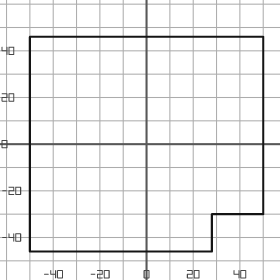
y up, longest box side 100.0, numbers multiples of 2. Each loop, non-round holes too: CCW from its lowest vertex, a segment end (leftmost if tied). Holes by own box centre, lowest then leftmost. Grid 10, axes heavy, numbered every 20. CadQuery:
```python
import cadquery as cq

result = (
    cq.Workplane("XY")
    .moveTo(-50.0, -46.0)
    .lineTo(28.0, -46.0)
    .lineTo(28.0, -30.0)
    .lineTo(50.0, -30.0)
    .lineTo(50.0, 46.0)
    .lineTo(-50.0, 46.0)
    .close()
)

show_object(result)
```